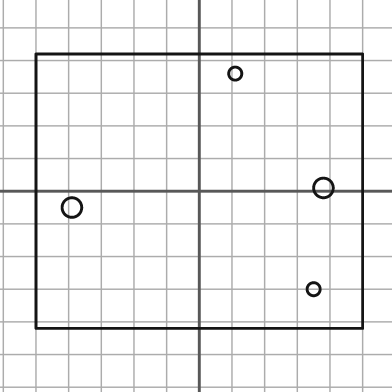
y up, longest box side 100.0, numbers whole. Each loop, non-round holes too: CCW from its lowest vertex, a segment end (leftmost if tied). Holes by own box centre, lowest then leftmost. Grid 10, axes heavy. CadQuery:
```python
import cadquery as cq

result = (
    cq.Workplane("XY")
    .moveTo(-50.0, -42.0)
    .lineTo(50.0, -42.0)
    .lineTo(50.0, 42.0)
    .lineTo(-50.0, 42.0)
    .close()
    .moveTo(35.0, -30.0)
    .circle(2.0)
    .moveTo(-39.0, -5.0)
    .circle(3.0)
    .moveTo(38.0, 1.0)
    .circle(3.0)
    .moveTo(11.0, 36.0)
    .circle(2.0)
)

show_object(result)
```